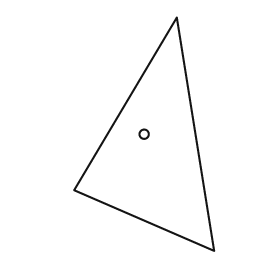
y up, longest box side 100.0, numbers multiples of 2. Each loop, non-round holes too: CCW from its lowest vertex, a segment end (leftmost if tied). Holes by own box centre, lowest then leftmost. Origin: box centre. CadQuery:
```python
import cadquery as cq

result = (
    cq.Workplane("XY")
    .moveTo(30.0, -50.0)
    .lineTo(14.0, 50.0)
    .lineTo(-30.0, -24.0)
    .close()
    .moveTo(0.0, 0.0)
    .circle(2.0)
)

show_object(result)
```